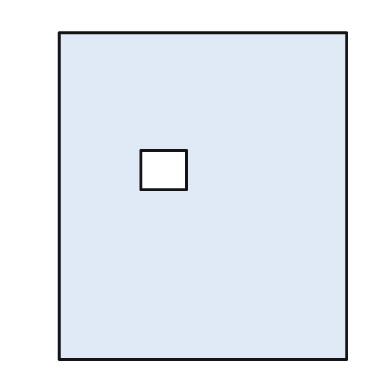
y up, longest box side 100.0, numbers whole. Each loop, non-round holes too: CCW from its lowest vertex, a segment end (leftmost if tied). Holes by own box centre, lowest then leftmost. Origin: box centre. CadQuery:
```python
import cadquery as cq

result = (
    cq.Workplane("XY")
    .moveTo(-44.0, -50.0)
    .lineTo(44.0, -50.0)
    .lineTo(44.0, 50.0)
    .lineTo(-44.0, 50.0)
    .close()
    .moveTo(-19.0, 2.0)
    .lineTo(-5.0, 2.0)
    .lineTo(-5.0, 14.0)
    .lineTo(-19.0, 14.0)
    .close()
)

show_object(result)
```